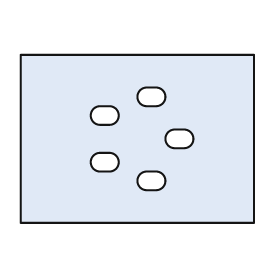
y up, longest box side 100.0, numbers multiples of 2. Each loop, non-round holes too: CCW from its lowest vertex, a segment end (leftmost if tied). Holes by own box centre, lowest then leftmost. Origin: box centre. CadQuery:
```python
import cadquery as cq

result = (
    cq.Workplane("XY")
    .moveTo(-50.0, -36.0)
    .lineTo(50.0, -36.0)
    .lineTo(50.0, 36.0)
    .lineTo(-50.0, 36.0)
    .close()
    .moveTo(4.0, -22.0)
    .lineTo(8.0, -22.0)
    .threePointArc((12.0, -18.0), (8.0, -14.0))
    .lineTo(4.0, -14.0)
    .threePointArc((0.0, -18.0), (4.0, -22.0))
    .close()
    .moveTo(-16.0, -14.0)
    .lineTo(-12.0, -14.0)
    .threePointArc((-8.0, -10.0), (-12.0, -6.0))
    .lineTo(-16.0, -6.0)
    .threePointArc((-20.0, -10.0), (-16.0, -14.0))
    .close()
    .moveTo(16.0, -4.0)
    .lineTo(20.0, -4.0)
    .threePointArc((24.0, 0.0), (20.0, 4.0))
    .lineTo(16.0, 4.0)
    .threePointArc((12.0, 0.0), (16.0, -4.0))
    .close()
    .moveTo(-16.0, 6.0)
    .lineTo(-12.0, 6.0)
    .threePointArc((-8.0, 10.0), (-12.0, 14.0))
    .lineTo(-16.0, 14.0)
    .threePointArc((-20.0, 10.0), (-16.0, 6.0))
    .close()
    .moveTo(4.0, 14.0)
    .lineTo(8.0, 14.0)
    .threePointArc((12.0, 18.0), (8.0, 22.0))
    .lineTo(4.0, 22.0)
    .threePointArc((0.0, 18.0), (4.0, 14.0))
    .close()
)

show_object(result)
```